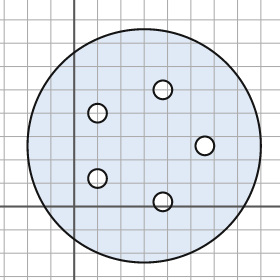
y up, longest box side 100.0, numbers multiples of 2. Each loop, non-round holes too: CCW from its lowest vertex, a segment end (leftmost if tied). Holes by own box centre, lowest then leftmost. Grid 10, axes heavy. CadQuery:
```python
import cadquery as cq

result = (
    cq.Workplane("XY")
    .moveTo(30.0, 26.0)
    .circle(50.0)
    .moveTo(38.0, 2.0)
    .circle(4.0)
    .moveTo(10.0, 12.0)
    .circle(4.0)
    .moveTo(56.0, 26.0)
    .circle(4.0)
    .moveTo(10.0, 40.0)
    .circle(4.0)
    .moveTo(38.0, 50.0)
    .circle(4.0)
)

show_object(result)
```